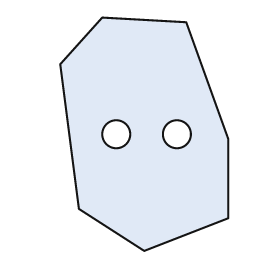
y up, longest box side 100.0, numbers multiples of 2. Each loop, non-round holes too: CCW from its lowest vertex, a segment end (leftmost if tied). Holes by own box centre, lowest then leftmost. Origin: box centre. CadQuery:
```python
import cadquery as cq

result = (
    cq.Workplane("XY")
    .moveTo(0.0, -50.0)
    .lineTo(36.0, -36.0)
    .lineTo(36.0, -2.0)
    .lineTo(18.0, 48.0)
    .lineTo(-18.0, 50.0)
    .lineTo(-36.0, 30.0)
    .lineTo(-28.0, -32.0)
    .close()
    .moveTo(-12.0, 0.0)
    .circle(6.0)
    .moveTo(14.0, 0.0)
    .circle(6.0)
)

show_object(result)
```